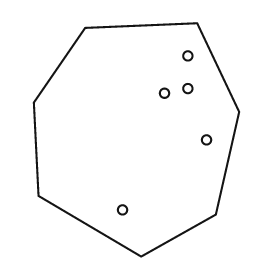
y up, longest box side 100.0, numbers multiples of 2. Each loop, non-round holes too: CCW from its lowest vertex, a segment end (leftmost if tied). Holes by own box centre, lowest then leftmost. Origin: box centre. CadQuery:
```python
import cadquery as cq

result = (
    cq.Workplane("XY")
    .moveTo(2.0, -50.0)
    .lineTo(34.0, -32.0)
    .lineTo(44.0, 12.0)
    .lineTo(26.0, 50.0)
    .lineTo(-22.0, 48.0)
    .lineTo(-44.0, 16.0)
    .lineTo(-42.0, -24.0)
    .close()
    .moveTo(-6.0, -30.0)
    .circle(2.0)
    .moveTo(30.0, 0.0)
    .circle(2.0)
    .moveTo(12.0, 20.0)
    .circle(2.0)
    .moveTo(22.0, 22.0)
    .circle(2.0)
    .moveTo(22.0, 36.0)
    .circle(2.0)
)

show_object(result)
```